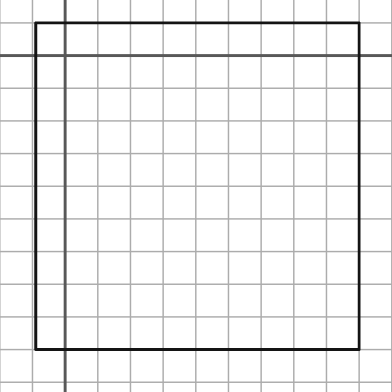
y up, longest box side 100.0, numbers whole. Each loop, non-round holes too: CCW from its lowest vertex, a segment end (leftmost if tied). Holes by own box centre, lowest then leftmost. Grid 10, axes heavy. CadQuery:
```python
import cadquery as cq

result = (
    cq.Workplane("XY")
    .moveTo(-9.0, -90.0)
    .lineTo(90.0, -90.0)
    .lineTo(90.0, 10.0)
    .lineTo(-9.0, 10.0)
    .close()
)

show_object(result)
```